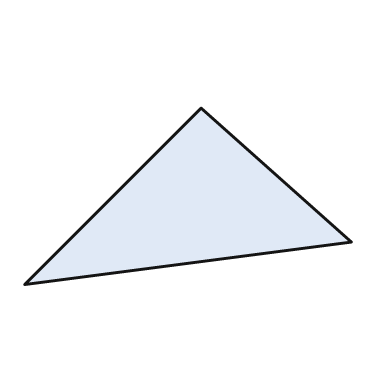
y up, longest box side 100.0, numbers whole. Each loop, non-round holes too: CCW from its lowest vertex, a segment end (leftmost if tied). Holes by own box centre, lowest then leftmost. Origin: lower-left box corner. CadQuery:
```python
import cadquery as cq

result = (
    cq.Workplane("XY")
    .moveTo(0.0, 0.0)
    .lineTo(100.0, 13.0)
    .lineTo(54.0, 54.0)
    .close()
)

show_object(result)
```